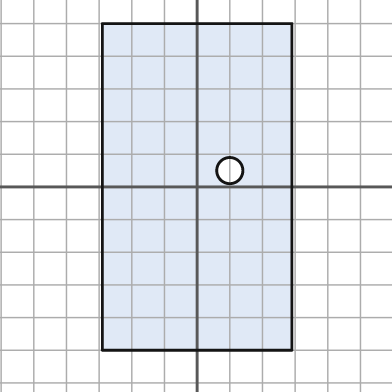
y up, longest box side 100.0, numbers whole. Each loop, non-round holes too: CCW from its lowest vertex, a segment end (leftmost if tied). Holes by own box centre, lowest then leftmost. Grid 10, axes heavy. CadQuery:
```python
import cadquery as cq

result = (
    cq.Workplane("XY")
    .moveTo(-29.0, -50.0)
    .lineTo(29.0, -50.0)
    .lineTo(29.0, 50.0)
    .lineTo(-29.0, 50.0)
    .close()
    .moveTo(10.0, 5.0)
    .circle(4.0)
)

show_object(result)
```